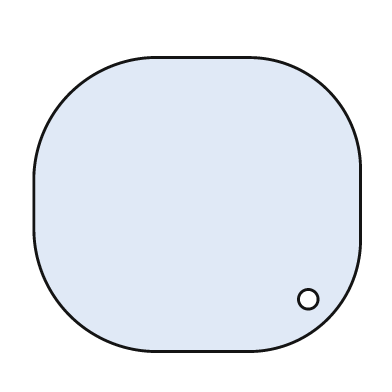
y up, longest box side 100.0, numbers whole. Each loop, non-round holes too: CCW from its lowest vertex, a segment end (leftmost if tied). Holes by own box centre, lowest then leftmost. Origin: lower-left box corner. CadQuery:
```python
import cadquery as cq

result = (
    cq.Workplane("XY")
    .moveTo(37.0, 0.0)
    .lineTo(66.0, 0.0)
    .threePointArc((90.0, 10.0), (100.0, 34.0))
    .lineTo(100.0, 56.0)
    .threePointArc((90.0, 80.0), (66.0, 90.0))
    .lineTo(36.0, 90.0)
    .threePointArc((11.0, 79.0), (0.0, 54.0))
    .lineTo(0.0, 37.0)
    .threePointArc((11.0, 11.0), (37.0, 0.0))
    .close()
    .moveTo(84.0, 16.0)
    .circle(3.0)
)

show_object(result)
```